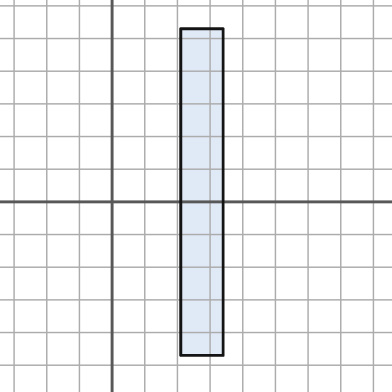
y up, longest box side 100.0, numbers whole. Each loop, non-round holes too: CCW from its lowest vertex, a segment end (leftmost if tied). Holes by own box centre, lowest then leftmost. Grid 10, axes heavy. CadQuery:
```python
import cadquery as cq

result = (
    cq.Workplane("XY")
    .moveTo(21.0, -47.0)
    .lineTo(34.0, -47.0)
    .lineTo(34.0, 53.0)
    .lineTo(21.0, 53.0)
    .close()
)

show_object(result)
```